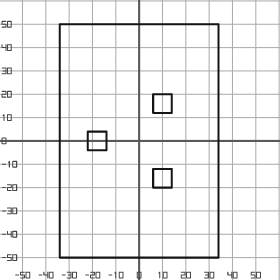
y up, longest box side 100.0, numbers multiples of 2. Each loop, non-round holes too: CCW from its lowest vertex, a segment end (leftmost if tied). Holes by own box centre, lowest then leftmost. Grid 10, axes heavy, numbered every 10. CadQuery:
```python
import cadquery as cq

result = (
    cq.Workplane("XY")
    .moveTo(-34.0, -50.0)
    .lineTo(34.0, -50.0)
    .lineTo(34.0, 50.0)
    .lineTo(-34.0, 50.0)
    .close()
    .moveTo(6.0, -20.0)
    .lineTo(14.0, -20.0)
    .lineTo(14.0, -12.0)
    .lineTo(6.0, -12.0)
    .close()
    .moveTo(-22.0, -4.0)
    .lineTo(-14.0, -4.0)
    .lineTo(-14.0, 4.0)
    .lineTo(-22.0, 4.0)
    .close()
    .moveTo(6.0, 12.0)
    .lineTo(14.0, 12.0)
    .lineTo(14.0, 20.0)
    .lineTo(6.0, 20.0)
    .close()
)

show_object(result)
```